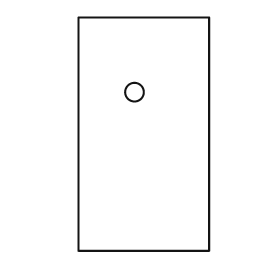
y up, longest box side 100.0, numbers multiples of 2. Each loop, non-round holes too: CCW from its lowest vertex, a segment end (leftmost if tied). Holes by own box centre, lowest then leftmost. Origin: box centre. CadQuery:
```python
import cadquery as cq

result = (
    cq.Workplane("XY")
    .moveTo(-28.0, -50.0)
    .lineTo(28.0, -50.0)
    .lineTo(28.0, 50.0)
    .lineTo(-28.0, 50.0)
    .close()
    .moveTo(-4.0, 18.0)
    .circle(4.0)
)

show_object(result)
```